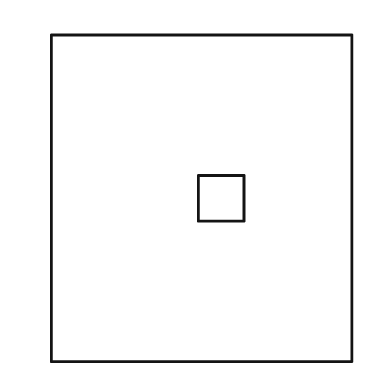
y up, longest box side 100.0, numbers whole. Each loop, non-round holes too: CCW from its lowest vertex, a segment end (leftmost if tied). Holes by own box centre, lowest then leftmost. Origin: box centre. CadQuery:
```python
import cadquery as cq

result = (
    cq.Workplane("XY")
    .moveTo(-46.0, -50.0)
    .lineTo(46.0, -50.0)
    .lineTo(46.0, 50.0)
    .lineTo(-46.0, 50.0)
    .close()
    .moveTo(-1.0, -7.0)
    .lineTo(13.0, -7.0)
    .lineTo(13.0, 7.0)
    .lineTo(-1.0, 7.0)
    .close()
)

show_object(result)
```